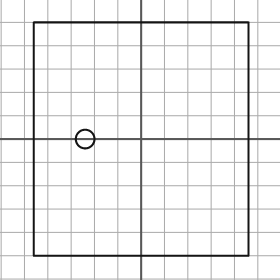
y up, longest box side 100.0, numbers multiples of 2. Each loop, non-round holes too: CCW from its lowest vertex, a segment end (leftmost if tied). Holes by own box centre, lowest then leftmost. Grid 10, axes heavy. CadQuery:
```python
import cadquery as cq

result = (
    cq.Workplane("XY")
    .moveTo(-46.0, -50.0)
    .lineTo(46.0, -50.0)
    .lineTo(46.0, 50.0)
    .lineTo(-46.0, 50.0)
    .close()
    .moveTo(-24.0, 0.0)
    .circle(4.0)
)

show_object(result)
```